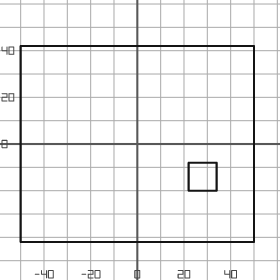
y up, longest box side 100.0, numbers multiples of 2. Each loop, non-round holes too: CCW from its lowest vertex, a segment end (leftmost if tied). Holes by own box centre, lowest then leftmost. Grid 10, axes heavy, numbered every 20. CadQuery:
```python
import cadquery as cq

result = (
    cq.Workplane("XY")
    .moveTo(-50.0, -42.0)
    .lineTo(50.0, -42.0)
    .lineTo(50.0, 42.0)
    .lineTo(-50.0, 42.0)
    .close()
    .moveTo(22.0, -20.0)
    .lineTo(34.0, -20.0)
    .lineTo(34.0, -8.0)
    .lineTo(22.0, -8.0)
    .close()
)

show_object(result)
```